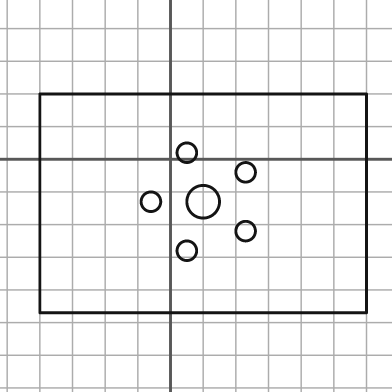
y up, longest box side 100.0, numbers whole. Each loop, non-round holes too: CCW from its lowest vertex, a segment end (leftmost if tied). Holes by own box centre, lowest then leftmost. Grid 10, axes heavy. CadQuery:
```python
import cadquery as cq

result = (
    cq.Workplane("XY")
    .moveTo(-40.0, -47.0)
    .lineTo(60.0, -47.0)
    .lineTo(60.0, 20.0)
    .lineTo(-40.0, 20.0)
    .close()
    .moveTo(5.0, -28.0)
    .circle(3.0)
    .moveTo(23.0, -22.0)
    .circle(3.0)
    .moveTo(-6.0, -13.0)
    .circle(3.0)
    .moveTo(10.0, -13.0)
    .circle(5.0)
    .moveTo(23.0, -4.0)
    .circle(3.0)
    .moveTo(5.0, 2.0)
    .circle(3.0)
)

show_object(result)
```